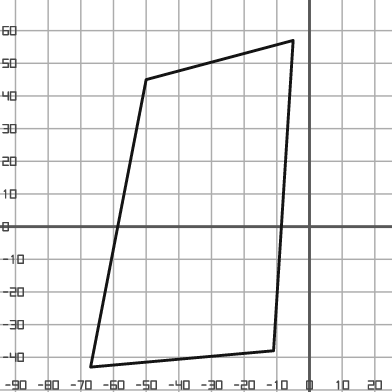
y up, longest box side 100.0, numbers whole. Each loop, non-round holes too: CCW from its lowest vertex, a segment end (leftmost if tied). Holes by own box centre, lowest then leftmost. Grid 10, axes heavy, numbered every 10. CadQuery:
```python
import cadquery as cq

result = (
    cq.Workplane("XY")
    .moveTo(-67.0, -43.0)
    .lineTo(-11.0, -38.0)
    .lineTo(-5.0, 57.0)
    .lineTo(-50.0, 45.0)
    .close()
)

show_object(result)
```